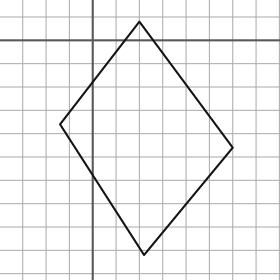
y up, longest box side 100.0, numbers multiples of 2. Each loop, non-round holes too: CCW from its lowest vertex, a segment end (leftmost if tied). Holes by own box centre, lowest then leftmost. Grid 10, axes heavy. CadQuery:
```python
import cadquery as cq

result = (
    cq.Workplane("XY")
    .moveTo(22.0, -92.0)
    .lineTo(60.0, -46.0)
    .lineTo(20.0, 8.0)
    .lineTo(-14.0, -36.0)
    .close()
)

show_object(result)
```